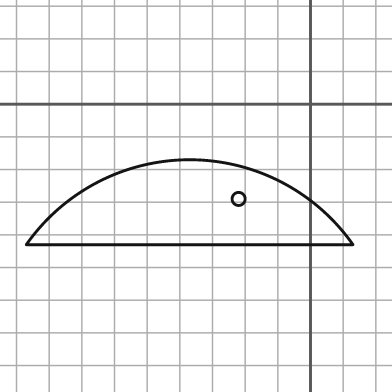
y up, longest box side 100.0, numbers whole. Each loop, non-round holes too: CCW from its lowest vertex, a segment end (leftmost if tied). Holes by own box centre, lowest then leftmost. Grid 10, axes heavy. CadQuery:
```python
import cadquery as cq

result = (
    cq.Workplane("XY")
    .moveTo(-87.0, -43.0)
    .lineTo(13.0, -43.0)
    .threePointArc((-37.0, -17.0), (-87.0, -43.0))
    .close()
    .moveTo(-22.0, -29.0)
    .circle(2.0)
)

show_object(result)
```